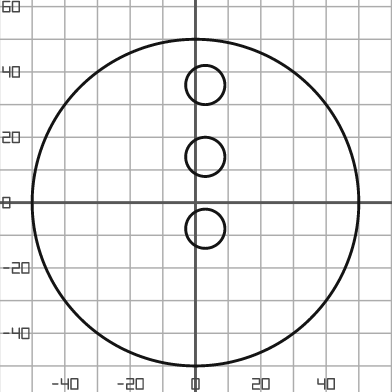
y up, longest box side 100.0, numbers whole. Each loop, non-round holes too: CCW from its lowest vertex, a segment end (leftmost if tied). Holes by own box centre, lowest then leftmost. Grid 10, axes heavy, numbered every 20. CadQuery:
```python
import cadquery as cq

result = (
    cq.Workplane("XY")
    .moveTo(0.0, 0.0)
    .circle(50.0)
    .moveTo(3.0, -8.0)
    .circle(6.0)
    .moveTo(3.0, 14.0)
    .circle(6.0)
    .moveTo(3.0, 36.0)
    .circle(6.0)
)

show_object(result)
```